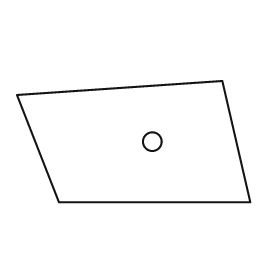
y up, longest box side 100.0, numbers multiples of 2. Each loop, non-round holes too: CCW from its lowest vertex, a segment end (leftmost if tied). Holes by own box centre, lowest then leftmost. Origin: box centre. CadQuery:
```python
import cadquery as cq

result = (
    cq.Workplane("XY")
    .moveTo(-32.0, -26.0)
    .lineTo(50.0, -26.0)
    .lineTo(38.0, 26.0)
    .lineTo(-50.0, 20.0)
    .close()
    .moveTo(8.0, 0.0)
    .circle(4.0)
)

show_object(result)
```